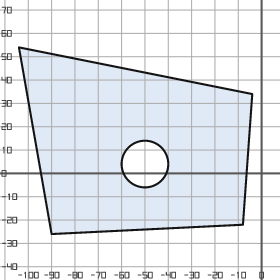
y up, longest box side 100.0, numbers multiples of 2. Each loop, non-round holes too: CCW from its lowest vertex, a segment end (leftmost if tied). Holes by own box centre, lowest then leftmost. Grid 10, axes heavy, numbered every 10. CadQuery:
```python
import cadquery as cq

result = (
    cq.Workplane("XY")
    .moveTo(-90.0, -26.0)
    .lineTo(-8.0, -22.0)
    .lineTo(-4.0, 34.0)
    .lineTo(-104.0, 54.0)
    .close()
    .moveTo(-50.0, 4.0)
    .circle(10.0)
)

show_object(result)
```